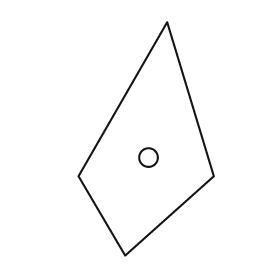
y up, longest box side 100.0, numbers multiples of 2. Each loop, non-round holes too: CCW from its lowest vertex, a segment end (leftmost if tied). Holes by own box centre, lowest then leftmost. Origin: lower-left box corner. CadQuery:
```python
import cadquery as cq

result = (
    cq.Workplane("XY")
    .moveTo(20.0, 0.0)
    .lineTo(58.0, 34.0)
    .lineTo(38.0, 100.0)
    .lineTo(0.0, 34.0)
    .close()
    .moveTo(30.0, 42.0)
    .circle(4.0)
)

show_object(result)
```